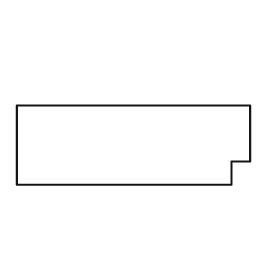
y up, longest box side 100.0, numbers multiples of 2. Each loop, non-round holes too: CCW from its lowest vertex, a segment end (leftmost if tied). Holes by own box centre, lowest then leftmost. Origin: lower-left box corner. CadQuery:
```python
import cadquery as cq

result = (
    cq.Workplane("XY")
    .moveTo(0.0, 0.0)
    .lineTo(92.0, 0.0)
    .lineTo(92.0, 10.0)
    .lineTo(100.0, 10.0)
    .lineTo(100.0, 34.0)
    .lineTo(0.0, 34.0)
    .close()
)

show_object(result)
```